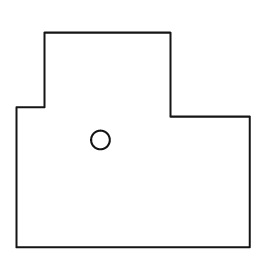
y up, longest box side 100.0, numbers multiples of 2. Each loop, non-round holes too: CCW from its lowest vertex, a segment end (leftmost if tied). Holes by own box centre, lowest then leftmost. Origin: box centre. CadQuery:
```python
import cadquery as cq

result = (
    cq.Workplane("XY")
    .moveTo(-50.0, -46.0)
    .lineTo(50.0, -46.0)
    .lineTo(50.0, 10.0)
    .lineTo(16.0, 10.0)
    .lineTo(16.0, 46.0)
    .lineTo(-38.0, 46.0)
    .lineTo(-38.0, 14.0)
    .lineTo(-50.0, 14.0)
    .close()
    .moveTo(-14.0, 0.0)
    .circle(4.0)
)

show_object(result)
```